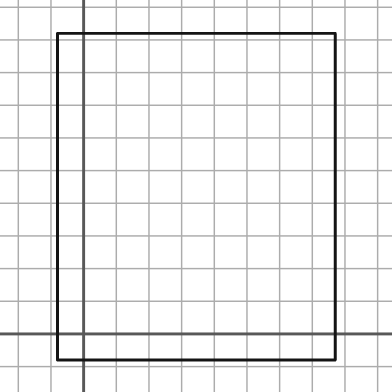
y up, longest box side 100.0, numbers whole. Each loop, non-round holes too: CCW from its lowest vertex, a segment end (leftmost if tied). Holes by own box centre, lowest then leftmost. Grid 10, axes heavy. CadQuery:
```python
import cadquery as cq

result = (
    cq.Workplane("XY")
    .moveTo(-8.0, -8.0)
    .lineTo(77.0, -8.0)
    .lineTo(77.0, 92.0)
    .lineTo(-8.0, 92.0)
    .close()
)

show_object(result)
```